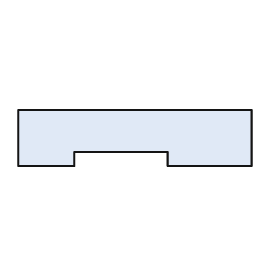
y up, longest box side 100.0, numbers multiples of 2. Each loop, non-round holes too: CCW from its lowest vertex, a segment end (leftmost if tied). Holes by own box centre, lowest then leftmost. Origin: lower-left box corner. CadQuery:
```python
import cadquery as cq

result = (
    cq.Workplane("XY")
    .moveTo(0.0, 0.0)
    .lineTo(24.0, 0.0)
    .lineTo(24.0, 6.0)
    .lineTo(64.0, 6.0)
    .lineTo(64.0, 0.0)
    .lineTo(100.0, 0.0)
    .lineTo(100.0, 24.0)
    .lineTo(0.0, 24.0)
    .close()
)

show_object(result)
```